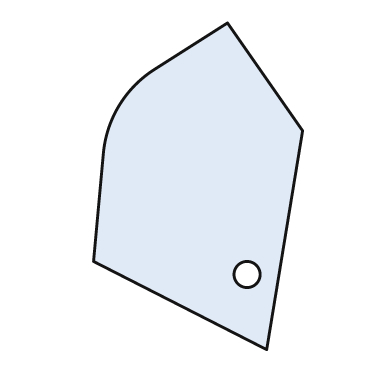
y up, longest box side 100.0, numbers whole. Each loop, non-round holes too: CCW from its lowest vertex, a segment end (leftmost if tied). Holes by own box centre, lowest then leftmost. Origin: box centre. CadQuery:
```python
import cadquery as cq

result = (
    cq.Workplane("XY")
    .moveTo(21.0, -50.0)
    .lineTo(32.0, 17.0)
    .lineTo(9.0, 50.0)
    .lineTo(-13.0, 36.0)
    .threePointArc((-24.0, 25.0), (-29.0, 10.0))
    .lineTo(-32.0, -23.0)
    .close()
    .moveTo(15.0, -27.0)
    .circle(4.0)
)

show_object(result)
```